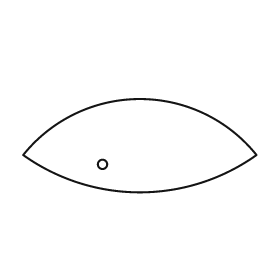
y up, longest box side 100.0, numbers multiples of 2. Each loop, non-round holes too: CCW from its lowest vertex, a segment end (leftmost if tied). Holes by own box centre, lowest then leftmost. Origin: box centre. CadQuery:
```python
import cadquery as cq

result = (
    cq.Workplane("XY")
    .moveTo(-50.0, -4.0)
    .threePointArc((0.0, -20.0), (50.0, -4.0))
    .threePointArc((0.0, 20.0), (-50.0, -4.0))
    .close()
    .moveTo(-16.0, -8.0)
    .circle(2.0)
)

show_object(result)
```